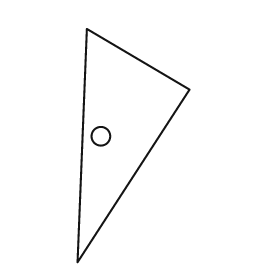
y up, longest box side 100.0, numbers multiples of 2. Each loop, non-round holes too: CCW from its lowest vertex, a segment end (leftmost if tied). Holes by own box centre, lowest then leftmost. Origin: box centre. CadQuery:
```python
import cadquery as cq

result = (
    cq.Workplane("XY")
    .moveTo(-24.0, -50.0)
    .lineTo(24.0, 24.0)
    .lineTo(-20.0, 50.0)
    .close()
    .moveTo(-14.0, 4.0)
    .circle(4.0)
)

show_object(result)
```